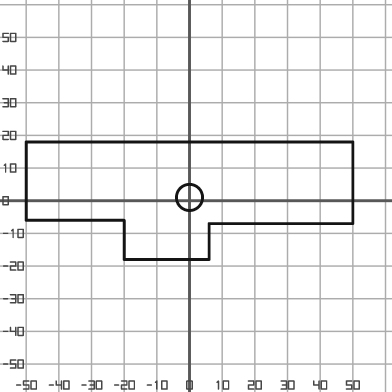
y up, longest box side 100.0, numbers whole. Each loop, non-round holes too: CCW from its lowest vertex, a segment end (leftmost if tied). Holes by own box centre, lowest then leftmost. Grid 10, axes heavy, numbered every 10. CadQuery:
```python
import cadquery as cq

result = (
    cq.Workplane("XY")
    .moveTo(-20.0, -18.0)
    .lineTo(6.0, -18.0)
    .lineTo(6.0, -7.0)
    .lineTo(50.0, -7.0)
    .lineTo(50.0, 18.0)
    .lineTo(-50.0, 18.0)
    .lineTo(-50.0, -6.0)
    .lineTo(-20.0, -6.0)
    .close()
    .moveTo(0.0, 1.0)
    .circle(4.0)
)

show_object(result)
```